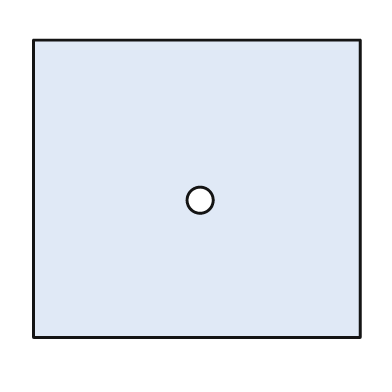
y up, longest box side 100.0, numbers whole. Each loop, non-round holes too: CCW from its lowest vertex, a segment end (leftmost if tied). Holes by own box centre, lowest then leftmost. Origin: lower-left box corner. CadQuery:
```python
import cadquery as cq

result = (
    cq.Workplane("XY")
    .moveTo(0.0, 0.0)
    .lineTo(100.0, 0.0)
    .lineTo(100.0, 91.0)
    .lineTo(0.0, 91.0)
    .close()
    .moveTo(51.0, 42.0)
    .circle(4.0)
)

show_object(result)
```